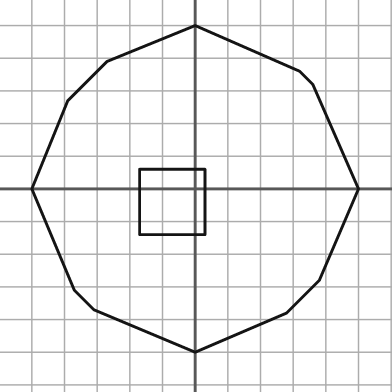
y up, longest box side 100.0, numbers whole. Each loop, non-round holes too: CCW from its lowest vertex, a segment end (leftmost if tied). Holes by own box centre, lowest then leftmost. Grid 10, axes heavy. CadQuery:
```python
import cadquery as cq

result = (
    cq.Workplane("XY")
    .moveTo(0.0, -50.0)
    .lineTo(28.0, -38.0)
    .lineTo(38.0, -28.0)
    .lineTo(50.0, 0.0)
    .lineTo(36.0, 32.0)
    .lineTo(32.0, 36.0)
    .lineTo(0.0, 50.0)
    .lineTo(-27.0, 39.0)
    .lineTo(-39.0, 27.0)
    .lineTo(-50.0, 0.0)
    .lineTo(-37.0, -31.0)
    .lineTo(-31.0, -37.0)
    .close()
    .moveTo(-17.0, -14.0)
    .lineTo(3.0, -14.0)
    .lineTo(3.0, 6.0)
    .lineTo(-17.0, 6.0)
    .close()
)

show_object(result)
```